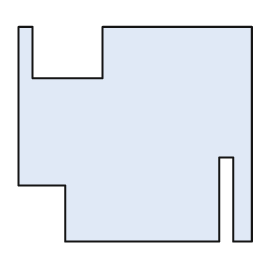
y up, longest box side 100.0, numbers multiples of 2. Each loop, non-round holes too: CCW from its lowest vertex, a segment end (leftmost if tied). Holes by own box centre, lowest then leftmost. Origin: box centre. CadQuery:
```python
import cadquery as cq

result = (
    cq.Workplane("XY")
    .moveTo(-30.0, -46.0)
    .lineTo(36.0, -46.0)
    .lineTo(36.0, -10.0)
    .lineTo(42.0, -10.0)
    .lineTo(42.0, -46.0)
    .lineTo(50.0, -46.0)
    .lineTo(50.0, 46.0)
    .lineTo(-14.0, 46.0)
    .lineTo(-14.0, 24.0)
    .lineTo(-44.0, 24.0)
    .lineTo(-44.0, 46.0)
    .lineTo(-50.0, 46.0)
    .lineTo(-50.0, -22.0)
    .lineTo(-30.0, -22.0)
    .close()
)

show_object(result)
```